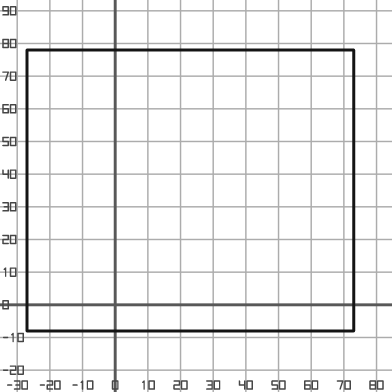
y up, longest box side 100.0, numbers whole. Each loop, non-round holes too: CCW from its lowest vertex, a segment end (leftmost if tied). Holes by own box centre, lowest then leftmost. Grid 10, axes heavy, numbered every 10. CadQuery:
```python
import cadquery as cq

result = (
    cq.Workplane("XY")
    .moveTo(-27.0, -8.0)
    .lineTo(73.0, -8.0)
    .lineTo(73.0, 78.0)
    .lineTo(-27.0, 78.0)
    .close()
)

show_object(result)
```